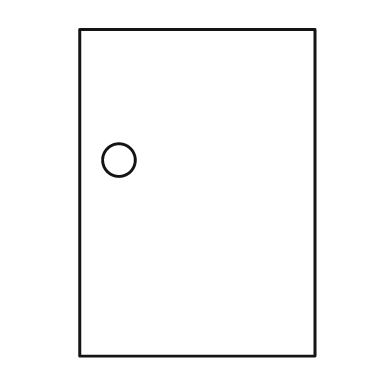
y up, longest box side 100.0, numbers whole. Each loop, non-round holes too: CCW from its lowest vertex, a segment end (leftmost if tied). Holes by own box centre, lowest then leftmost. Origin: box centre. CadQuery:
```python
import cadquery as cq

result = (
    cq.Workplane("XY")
    .moveTo(-36.0, -50.0)
    .lineTo(36.0, -50.0)
    .lineTo(36.0, 50.0)
    .lineTo(-36.0, 50.0)
    .close()
    .moveTo(-24.0, 10.0)
    .circle(5.0)
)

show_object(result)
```